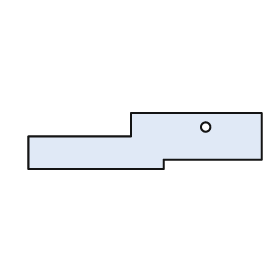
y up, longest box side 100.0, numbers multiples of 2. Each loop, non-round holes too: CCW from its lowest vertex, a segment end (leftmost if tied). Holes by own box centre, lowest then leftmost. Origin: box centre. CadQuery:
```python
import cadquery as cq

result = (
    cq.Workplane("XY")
    .moveTo(-50.0, -12.0)
    .lineTo(8.0, -12.0)
    .lineTo(8.0, -8.0)
    .lineTo(50.0, -8.0)
    .lineTo(50.0, 12.0)
    .lineTo(-6.0, 12.0)
    .lineTo(-6.0, 2.0)
    .lineTo(-50.0, 2.0)
    .close()
    .moveTo(26.0, 6.0)
    .circle(2.0)
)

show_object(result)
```